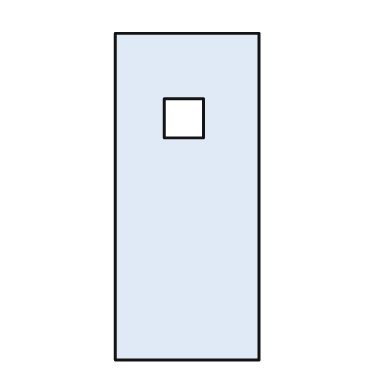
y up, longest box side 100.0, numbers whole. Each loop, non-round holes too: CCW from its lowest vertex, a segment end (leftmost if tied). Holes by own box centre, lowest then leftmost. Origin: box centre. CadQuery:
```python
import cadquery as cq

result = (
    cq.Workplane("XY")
    .moveTo(-22.0, -50.0)
    .lineTo(22.0, -50.0)
    .lineTo(22.0, 50.0)
    .lineTo(-22.0, 50.0)
    .close()
    .moveTo(-7.0, 18.0)
    .lineTo(5.0, 18.0)
    .lineTo(5.0, 30.0)
    .lineTo(-7.0, 30.0)
    .close()
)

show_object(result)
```